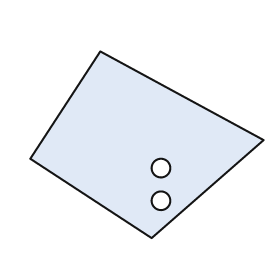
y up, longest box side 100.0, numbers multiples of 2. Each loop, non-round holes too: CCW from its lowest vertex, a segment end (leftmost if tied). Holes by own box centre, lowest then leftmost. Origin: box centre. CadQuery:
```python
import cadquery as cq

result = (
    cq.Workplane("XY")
    .moveTo(2.0, -40.0)
    .lineTo(50.0, 2.0)
    .lineTo(-20.0, 40.0)
    .lineTo(-50.0, -6.0)
    .close()
    .moveTo(6.0, -24.0)
    .circle(4.0)
    .moveTo(6.0, -10.0)
    .circle(4.0)
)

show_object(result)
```